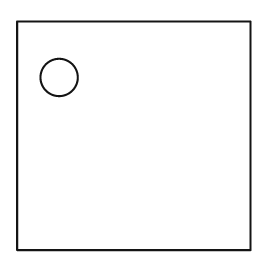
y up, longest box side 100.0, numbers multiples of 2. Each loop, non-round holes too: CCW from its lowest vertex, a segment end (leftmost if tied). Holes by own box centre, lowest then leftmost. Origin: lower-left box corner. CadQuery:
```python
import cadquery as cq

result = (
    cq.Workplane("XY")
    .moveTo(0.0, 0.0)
    .lineTo(100.0, 0.0)
    .lineTo(100.0, 98.0)
    .lineTo(0.0, 98.0)
    .close()
    .moveTo(18.0, 74.0)
    .circle(8.0)
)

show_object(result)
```